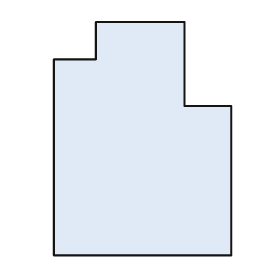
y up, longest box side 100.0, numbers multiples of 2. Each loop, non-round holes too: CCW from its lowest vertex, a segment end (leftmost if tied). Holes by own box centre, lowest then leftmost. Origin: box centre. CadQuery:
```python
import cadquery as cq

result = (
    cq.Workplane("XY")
    .moveTo(-38.0, -50.0)
    .lineTo(38.0, -50.0)
    .lineTo(38.0, 14.0)
    .lineTo(18.0, 14.0)
    .lineTo(18.0, 50.0)
    .lineTo(-20.0, 50.0)
    .lineTo(-20.0, 34.0)
    .lineTo(-38.0, 34.0)
    .close()
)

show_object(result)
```